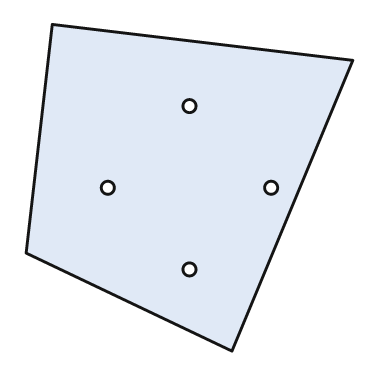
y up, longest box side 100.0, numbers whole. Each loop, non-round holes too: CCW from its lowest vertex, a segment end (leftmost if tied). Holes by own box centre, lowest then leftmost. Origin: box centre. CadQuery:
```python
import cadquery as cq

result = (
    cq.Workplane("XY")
    .moveTo(13.0, -50.0)
    .lineTo(50.0, 39.0)
    .lineTo(-42.0, 50.0)
    .lineTo(-50.0, -20.0)
    .close()
    .moveTo(0.0, -25.0)
    .circle(2.0)
    .moveTo(-25.0, 0.0)
    .circle(2.0)
    .moveTo(25.0, 0.0)
    .circle(2.0)
    .moveTo(0.0, 25.0)
    .circle(2.0)
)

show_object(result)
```